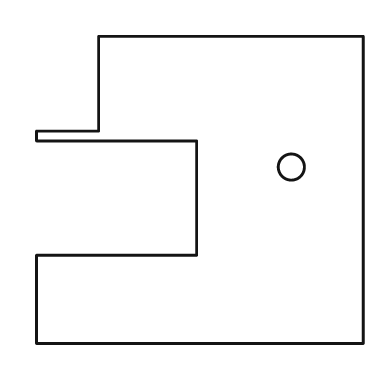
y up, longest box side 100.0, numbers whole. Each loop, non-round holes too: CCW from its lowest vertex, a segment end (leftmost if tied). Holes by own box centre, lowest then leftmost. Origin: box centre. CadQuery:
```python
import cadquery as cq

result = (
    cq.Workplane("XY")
    .moveTo(-50.0, -47.0)
    .lineTo(50.0, -47.0)
    .lineTo(50.0, 47.0)
    .lineTo(-31.0, 47.0)
    .lineTo(-31.0, 18.0)
    .lineTo(-50.0, 18.0)
    .lineTo(-50.0, 15.0)
    .lineTo(-1.0, 15.0)
    .lineTo(-1.0, -20.0)
    .lineTo(-50.0, -20.0)
    .close()
    .moveTo(28.0, 7.0)
    .circle(4.0)
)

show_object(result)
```